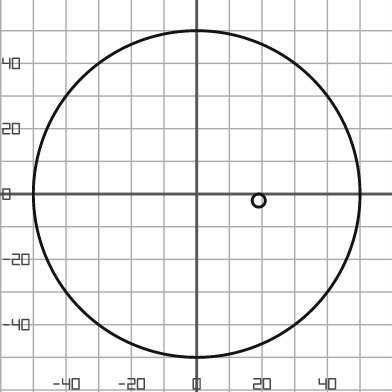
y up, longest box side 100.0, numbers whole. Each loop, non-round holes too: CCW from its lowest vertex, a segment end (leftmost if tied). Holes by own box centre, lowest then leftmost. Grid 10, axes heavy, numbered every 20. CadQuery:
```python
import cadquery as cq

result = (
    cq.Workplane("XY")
    .moveTo(0.0, 0.0)
    .circle(50.0)
    .moveTo(19.0, -2.0)
    .circle(2.0)
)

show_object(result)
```